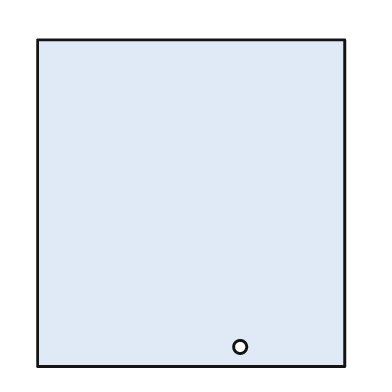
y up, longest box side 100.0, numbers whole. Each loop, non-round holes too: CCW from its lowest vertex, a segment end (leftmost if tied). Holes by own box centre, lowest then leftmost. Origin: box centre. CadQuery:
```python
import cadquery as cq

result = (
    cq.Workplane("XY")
    .moveTo(-47.0, -50.0)
    .lineTo(47.0, -50.0)
    .lineTo(47.0, 50.0)
    .lineTo(-47.0, 50.0)
    .close()
    .moveTo(15.0, -44.0)
    .circle(2.0)
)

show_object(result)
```